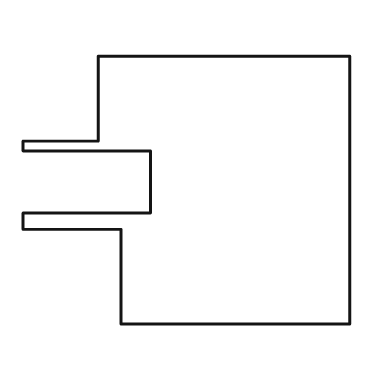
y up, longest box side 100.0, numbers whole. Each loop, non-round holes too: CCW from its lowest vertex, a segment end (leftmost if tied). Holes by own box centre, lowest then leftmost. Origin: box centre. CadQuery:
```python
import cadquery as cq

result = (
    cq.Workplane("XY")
    .moveTo(-20.0, -41.0)
    .lineTo(50.0, -41.0)
    .lineTo(50.0, 41.0)
    .lineTo(-27.0, 41.0)
    .lineTo(-27.0, 15.0)
    .lineTo(-50.0, 15.0)
    .lineTo(-50.0, 12.0)
    .lineTo(-11.0, 12.0)
    .lineTo(-11.0, -7.0)
    .lineTo(-50.0, -7.0)
    .lineTo(-50.0, -12.0)
    .lineTo(-20.0, -12.0)
    .close()
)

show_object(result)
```